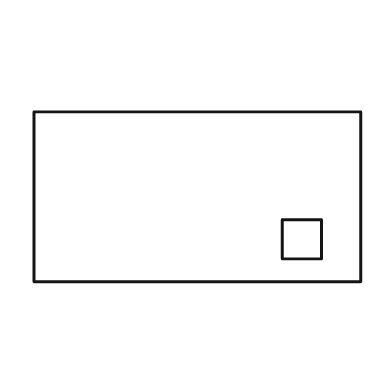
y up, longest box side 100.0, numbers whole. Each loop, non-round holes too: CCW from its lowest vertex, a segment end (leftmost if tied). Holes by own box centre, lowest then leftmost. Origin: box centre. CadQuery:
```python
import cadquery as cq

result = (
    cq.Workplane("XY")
    .moveTo(-50.0, -26.0)
    .lineTo(50.0, -26.0)
    .lineTo(50.0, 26.0)
    .lineTo(-50.0, 26.0)
    .close()
    .moveTo(26.0, -19.0)
    .lineTo(38.0, -19.0)
    .lineTo(38.0, -7.0)
    .lineTo(26.0, -7.0)
    .close()
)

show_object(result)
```